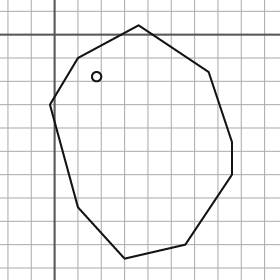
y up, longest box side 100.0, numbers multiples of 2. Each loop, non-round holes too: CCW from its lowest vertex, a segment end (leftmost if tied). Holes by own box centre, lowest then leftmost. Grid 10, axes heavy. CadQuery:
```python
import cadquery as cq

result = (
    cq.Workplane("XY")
    .moveTo(30.0, -96.0)
    .lineTo(56.0, -90.0)
    .lineTo(76.0, -60.0)
    .lineTo(76.0, -46.0)
    .lineTo(66.0, -16.0)
    .lineTo(36.0, 4.0)
    .lineTo(10.0, -10.0)
    .lineTo(-2.0, -30.0)
    .lineTo(10.0, -74.0)
    .close()
    .moveTo(18.0, -18.0)
    .circle(2.0)
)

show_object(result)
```